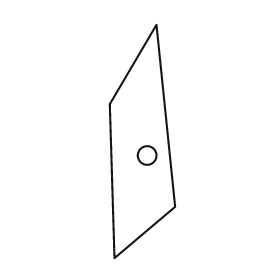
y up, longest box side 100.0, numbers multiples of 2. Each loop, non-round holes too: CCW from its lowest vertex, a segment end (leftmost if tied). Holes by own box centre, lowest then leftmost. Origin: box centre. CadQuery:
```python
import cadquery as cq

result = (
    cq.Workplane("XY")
    .moveTo(-12.0, -50.0)
    .lineTo(14.0, -28.0)
    .lineTo(6.0, 50.0)
    .lineTo(-14.0, 16.0)
    .close()
    .moveTo(2.0, -6.0)
    .circle(4.0)
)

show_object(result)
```